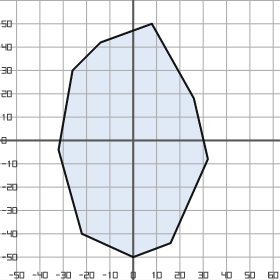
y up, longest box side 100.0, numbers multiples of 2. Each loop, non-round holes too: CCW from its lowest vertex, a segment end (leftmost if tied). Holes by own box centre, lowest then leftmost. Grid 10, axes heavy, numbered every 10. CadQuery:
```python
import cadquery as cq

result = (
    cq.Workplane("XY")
    .moveTo(0.0, -50.0)
    .lineTo(16.0, -44.0)
    .lineTo(32.0, -8.0)
    .lineTo(26.0, 18.0)
    .lineTo(8.0, 50.0)
    .lineTo(-14.0, 42.0)
    .lineTo(-26.0, 30.0)
    .lineTo(-32.0, -4.0)
    .lineTo(-22.0, -40.0)
    .close()
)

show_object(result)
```